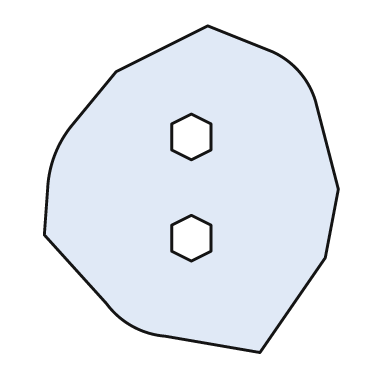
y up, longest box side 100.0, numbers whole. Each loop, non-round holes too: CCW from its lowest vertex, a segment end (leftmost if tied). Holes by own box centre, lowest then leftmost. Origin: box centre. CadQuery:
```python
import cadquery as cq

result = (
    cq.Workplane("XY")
    .moveTo(21.0, -50.0)
    .lineTo(41.0, -21.0)
    .lineTo(45.0, 0.0)
    .lineTo(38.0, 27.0)
    .threePointArc((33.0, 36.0), (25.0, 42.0))
    .lineTo(5.0, 50.0)
    .lineTo(-23.0, 36.0)
    .lineTo(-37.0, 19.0)
    .threePointArc((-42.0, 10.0), (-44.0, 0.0))
    .lineTo(-45.0, -14.0)
    .lineTo(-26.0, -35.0)
    .threePointArc((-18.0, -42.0), (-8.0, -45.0))
    .close()
    .moveTo(0.0, -22.0)
    .lineTo(6.0, -19.0)
    .lineTo(6.0, -11.0)
    .lineTo(0.0, -8.0)
    .lineTo(-6.0, -11.0)
    .lineTo(-6.0, -19.0)
    .close()
    .moveTo(0.0, 9.0)
    .lineTo(6.0, 12.0)
    .lineTo(6.0, 20.0)
    .lineTo(0.0, 23.0)
    .lineTo(-6.0, 20.0)
    .lineTo(-6.0, 12.0)
    .close()
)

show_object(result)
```